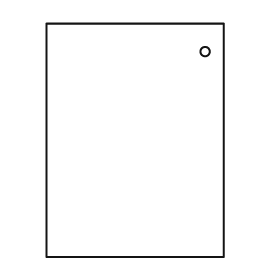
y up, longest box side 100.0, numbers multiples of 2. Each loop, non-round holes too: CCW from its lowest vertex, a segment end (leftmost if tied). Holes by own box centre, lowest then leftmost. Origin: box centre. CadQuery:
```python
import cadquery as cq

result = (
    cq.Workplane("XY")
    .moveTo(-38.0, -50.0)
    .lineTo(38.0, -50.0)
    .lineTo(38.0, 50.0)
    .lineTo(-38.0, 50.0)
    .close()
    .moveTo(30.0, 38.0)
    .circle(2.0)
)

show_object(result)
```